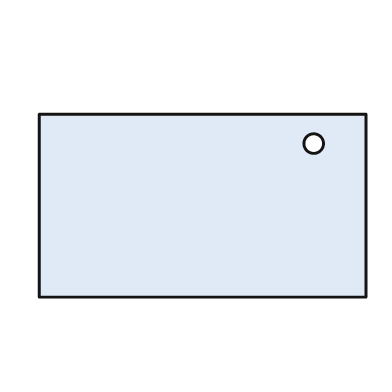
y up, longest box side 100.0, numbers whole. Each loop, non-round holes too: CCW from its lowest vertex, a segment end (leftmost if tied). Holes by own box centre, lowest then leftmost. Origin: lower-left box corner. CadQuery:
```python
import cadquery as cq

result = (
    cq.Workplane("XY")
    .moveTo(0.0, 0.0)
    .lineTo(100.0, 0.0)
    .lineTo(100.0, 56.0)
    .lineTo(0.0, 56.0)
    .close()
    .moveTo(84.0, 47.0)
    .circle(3.0)
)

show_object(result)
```